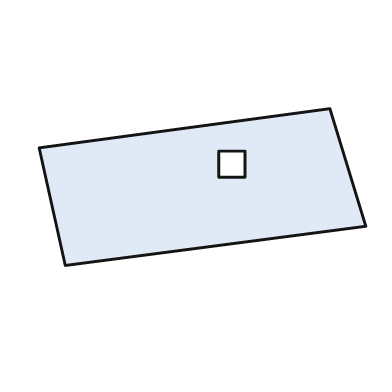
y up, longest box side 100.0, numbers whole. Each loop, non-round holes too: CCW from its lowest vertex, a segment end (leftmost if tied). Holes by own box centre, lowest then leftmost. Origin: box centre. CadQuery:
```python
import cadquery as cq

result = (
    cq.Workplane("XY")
    .moveTo(-42.0, -24.0)
    .lineTo(50.0, -12.0)
    .lineTo(39.0, 24.0)
    .lineTo(-50.0, 12.0)
    .close()
    .moveTo(5.0, 3.0)
    .lineTo(13.0, 3.0)
    .lineTo(13.0, 11.0)
    .lineTo(5.0, 11.0)
    .close()
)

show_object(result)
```